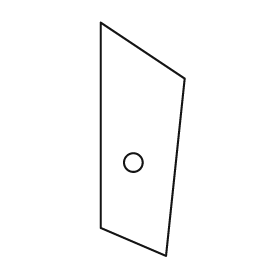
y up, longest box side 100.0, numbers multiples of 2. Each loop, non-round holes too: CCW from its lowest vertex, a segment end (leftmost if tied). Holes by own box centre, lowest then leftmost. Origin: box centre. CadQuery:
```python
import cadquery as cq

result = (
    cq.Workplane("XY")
    .moveTo(10.0, -50.0)
    .lineTo(18.0, 26.0)
    .lineTo(-18.0, 50.0)
    .lineTo(-18.0, -38.0)
    .close()
    .moveTo(-4.0, -10.0)
    .circle(4.0)
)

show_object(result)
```